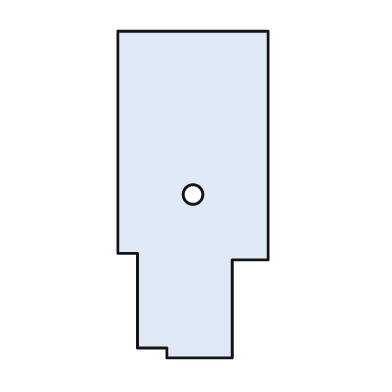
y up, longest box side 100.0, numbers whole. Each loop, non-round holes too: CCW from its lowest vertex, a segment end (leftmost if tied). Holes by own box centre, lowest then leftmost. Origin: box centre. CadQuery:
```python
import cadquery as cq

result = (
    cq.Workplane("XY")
    .moveTo(-8.0, -50.0)
    .lineTo(12.0, -50.0)
    .lineTo(12.0, -20.0)
    .lineTo(23.0, -20.0)
    .lineTo(23.0, 50.0)
    .lineTo(-23.0, 50.0)
    .lineTo(-23.0, -18.0)
    .lineTo(-17.0, -18.0)
    .lineTo(-17.0, -47.0)
    .lineTo(-8.0, -47.0)
    .close()
    .moveTo(0.0, 0.0)
    .circle(3.0)
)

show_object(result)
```